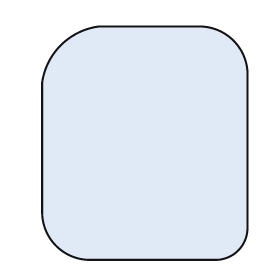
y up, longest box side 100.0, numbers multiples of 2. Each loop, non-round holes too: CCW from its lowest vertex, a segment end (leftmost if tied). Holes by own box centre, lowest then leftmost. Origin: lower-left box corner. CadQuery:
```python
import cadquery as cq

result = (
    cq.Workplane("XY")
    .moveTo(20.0, 0.0)
    .lineTo(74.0, 0.0)
    .threePointArc((84.0, 4.0), (88.0, 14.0))
    .lineTo(88.0, 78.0)
    .threePointArc((82.0, 94.0), (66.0, 100.0))
    .lineTo(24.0, 100.0)
    .threePointArc((8.0, 92.0), (0.0, 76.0))
    .lineTo(0.0, 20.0)
    .threePointArc((6.0, 6.0), (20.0, 0.0))
    .close()
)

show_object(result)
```